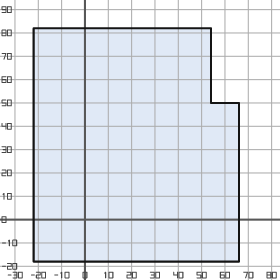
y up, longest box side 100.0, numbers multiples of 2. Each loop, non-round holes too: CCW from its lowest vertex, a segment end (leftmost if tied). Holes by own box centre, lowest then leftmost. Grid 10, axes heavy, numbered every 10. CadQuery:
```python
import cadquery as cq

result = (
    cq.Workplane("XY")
    .moveTo(-22.0, -18.0)
    .lineTo(66.0, -18.0)
    .lineTo(66.0, 50.0)
    .lineTo(54.0, 50.0)
    .lineTo(54.0, 82.0)
    .lineTo(-22.0, 82.0)
    .close()
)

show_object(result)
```